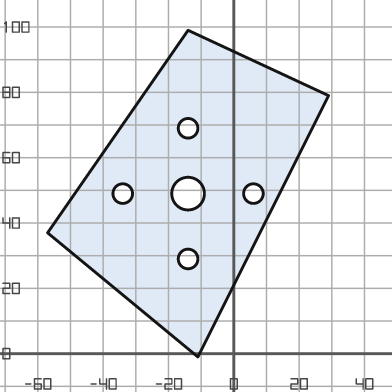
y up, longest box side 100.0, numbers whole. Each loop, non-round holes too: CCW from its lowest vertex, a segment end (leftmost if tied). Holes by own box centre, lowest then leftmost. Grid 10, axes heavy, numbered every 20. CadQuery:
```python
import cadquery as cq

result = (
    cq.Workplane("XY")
    .moveTo(-11.0, -1.0)
    .lineTo(29.0, 79.0)
    .lineTo(-14.0, 99.0)
    .lineTo(-57.0, 37.0)
    .close()
    .moveTo(-14.0, 29.0)
    .circle(3.0)
    .moveTo(-34.0, 49.0)
    .circle(3.0)
    .moveTo(-14.0, 49.0)
    .circle(5.0)
    .moveTo(6.0, 49.0)
    .circle(3.0)
    .moveTo(-14.0, 69.0)
    .circle(3.0)
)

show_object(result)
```